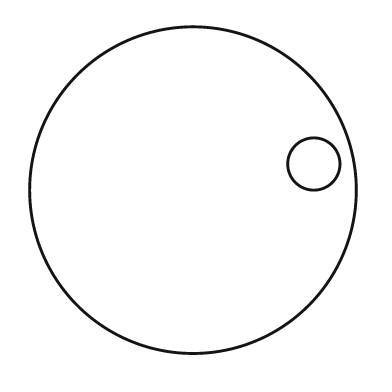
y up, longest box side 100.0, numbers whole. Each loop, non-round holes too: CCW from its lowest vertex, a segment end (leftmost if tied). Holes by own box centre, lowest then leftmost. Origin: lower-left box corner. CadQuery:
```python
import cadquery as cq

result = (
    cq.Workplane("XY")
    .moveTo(50.0, 50.0)
    .circle(50.0)
    .moveTo(87.0, 58.0)
    .circle(8.0)
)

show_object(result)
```